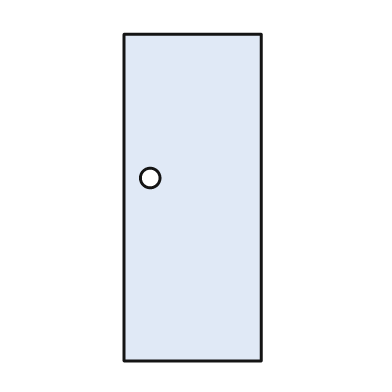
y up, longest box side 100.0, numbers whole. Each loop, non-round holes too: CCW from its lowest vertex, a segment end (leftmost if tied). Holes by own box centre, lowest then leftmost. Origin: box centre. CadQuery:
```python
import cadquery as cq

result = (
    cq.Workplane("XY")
    .moveTo(-21.0, -50.0)
    .lineTo(21.0, -50.0)
    .lineTo(21.0, 50.0)
    .lineTo(-21.0, 50.0)
    .close()
    .moveTo(-13.0, 6.0)
    .circle(3.0)
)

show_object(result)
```